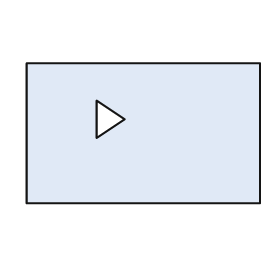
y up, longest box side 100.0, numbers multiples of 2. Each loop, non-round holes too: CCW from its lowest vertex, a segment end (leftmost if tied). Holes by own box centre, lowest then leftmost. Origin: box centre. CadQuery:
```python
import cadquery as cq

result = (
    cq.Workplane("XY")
    .moveTo(-50.0, -30.0)
    .lineTo(50.0, -30.0)
    .lineTo(50.0, 30.0)
    .lineTo(-50.0, 30.0)
    .close()
    .moveTo(-20.0, -2.0)
    .lineTo(-8.0, 6.0)
    .lineTo(-20.0, 14.0)
    .close()
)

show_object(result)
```